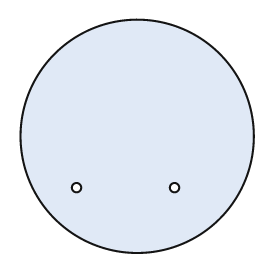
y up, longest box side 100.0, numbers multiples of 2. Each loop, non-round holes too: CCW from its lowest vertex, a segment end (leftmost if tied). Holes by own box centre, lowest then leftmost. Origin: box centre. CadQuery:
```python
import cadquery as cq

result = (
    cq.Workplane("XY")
    .moveTo(0.0, 0.0)
    .circle(50.0)
    .moveTo(-26.0, -22.0)
    .circle(2.0)
    .moveTo(16.0, -22.0)
    .circle(2.0)
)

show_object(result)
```